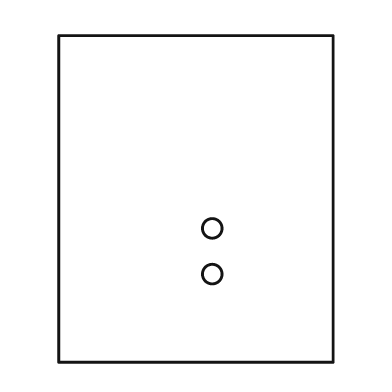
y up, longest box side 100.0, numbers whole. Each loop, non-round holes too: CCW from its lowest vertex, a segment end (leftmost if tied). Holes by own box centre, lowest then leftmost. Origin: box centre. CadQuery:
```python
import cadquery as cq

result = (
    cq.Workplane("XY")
    .moveTo(-42.0, -50.0)
    .lineTo(42.0, -50.0)
    .lineTo(42.0, 50.0)
    .lineTo(-42.0, 50.0)
    .close()
    .moveTo(5.0, -23.0)
    .circle(3.0)
    .moveTo(5.0, -9.0)
    .circle(3.0)
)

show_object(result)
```